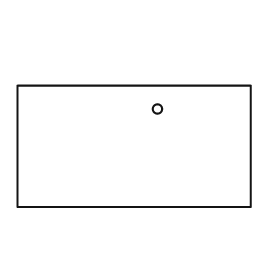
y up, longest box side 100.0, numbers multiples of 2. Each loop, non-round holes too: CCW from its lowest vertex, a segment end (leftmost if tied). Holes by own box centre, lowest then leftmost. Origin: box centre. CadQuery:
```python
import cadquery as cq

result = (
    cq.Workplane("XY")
    .moveTo(-50.0, -26.0)
    .lineTo(50.0, -26.0)
    .lineTo(50.0, 26.0)
    .lineTo(-50.0, 26.0)
    .close()
    .moveTo(10.0, 16.0)
    .circle(2.0)
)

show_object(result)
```